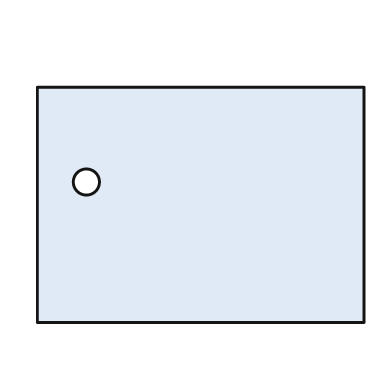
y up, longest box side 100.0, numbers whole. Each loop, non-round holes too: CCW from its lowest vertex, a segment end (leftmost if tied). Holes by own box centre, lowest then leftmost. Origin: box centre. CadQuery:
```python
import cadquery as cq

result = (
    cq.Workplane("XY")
    .moveTo(-50.0, -36.0)
    .lineTo(50.0, -36.0)
    .lineTo(50.0, 36.0)
    .lineTo(-50.0, 36.0)
    .close()
    .moveTo(-35.0, 7.0)
    .circle(4.0)
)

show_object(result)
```